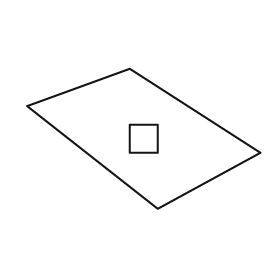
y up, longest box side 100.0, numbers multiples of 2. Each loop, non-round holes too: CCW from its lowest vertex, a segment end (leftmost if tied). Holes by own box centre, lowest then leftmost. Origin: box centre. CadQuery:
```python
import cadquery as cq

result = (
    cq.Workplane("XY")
    .moveTo(6.0, -30.0)
    .lineTo(50.0, -6.0)
    .lineTo(-6.0, 30.0)
    .lineTo(-50.0, 14.0)
    .close()
    .moveTo(-6.0, -6.0)
    .lineTo(6.0, -6.0)
    .lineTo(6.0, 6.0)
    .lineTo(-6.0, 6.0)
    .close()
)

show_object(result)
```